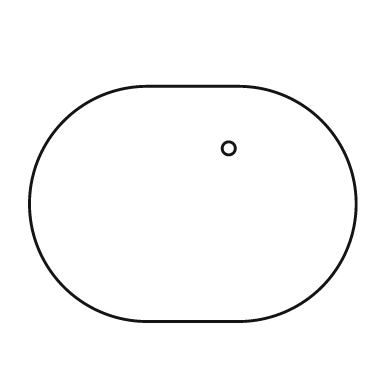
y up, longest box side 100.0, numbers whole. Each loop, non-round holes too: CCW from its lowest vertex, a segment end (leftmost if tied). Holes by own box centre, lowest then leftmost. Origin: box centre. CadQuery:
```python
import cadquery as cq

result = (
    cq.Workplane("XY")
    .moveTo(-14.0, -36.0)
    .lineTo(14.0, -36.0)
    .threePointArc((50.0, 0.0), (14.0, 36.0))
    .lineTo(-14.0, 36.0)
    .threePointArc((-50.0, 0.0), (-14.0, -36.0))
    .close()
    .moveTo(11.0, 17.0)
    .circle(2.0)
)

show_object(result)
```